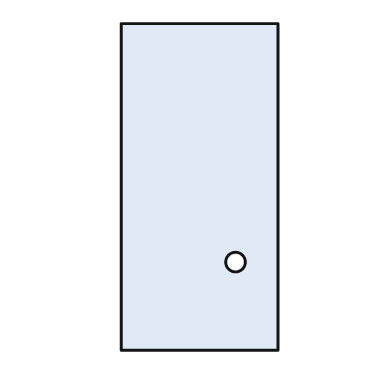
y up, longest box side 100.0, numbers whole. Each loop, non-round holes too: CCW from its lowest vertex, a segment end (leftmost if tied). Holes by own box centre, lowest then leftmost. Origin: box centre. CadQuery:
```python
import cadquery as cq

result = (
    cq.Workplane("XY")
    .moveTo(-24.0, -50.0)
    .lineTo(24.0, -50.0)
    .lineTo(24.0, 50.0)
    .lineTo(-24.0, 50.0)
    .close()
    .moveTo(11.0, -23.0)
    .circle(3.0)
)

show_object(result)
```